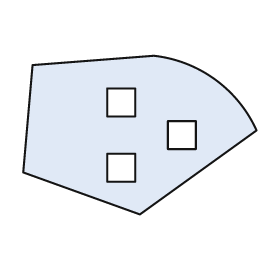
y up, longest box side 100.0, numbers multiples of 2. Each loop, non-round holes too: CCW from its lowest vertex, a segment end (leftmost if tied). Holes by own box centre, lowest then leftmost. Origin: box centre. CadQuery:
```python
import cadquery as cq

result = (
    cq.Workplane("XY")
    .moveTo(0.0, -34.0)
    .lineTo(50.0, 2.0)
    .threePointArc((32.0, 24.0), (6.0, 34.0))
    .lineTo(-46.0, 30.0)
    .lineTo(-50.0, -16.0)
    .close()
    .moveTo(-14.0, -20.0)
    .lineTo(-2.0, -20.0)
    .lineTo(-2.0, -8.0)
    .lineTo(-14.0, -8.0)
    .close()
    .moveTo(12.0, -6.0)
    .lineTo(24.0, -6.0)
    .lineTo(24.0, 6.0)
    .lineTo(12.0, 6.0)
    .close()
    .moveTo(-14.0, 8.0)
    .lineTo(-2.0, 8.0)
    .lineTo(-2.0, 20.0)
    .lineTo(-14.0, 20.0)
    .close()
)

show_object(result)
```